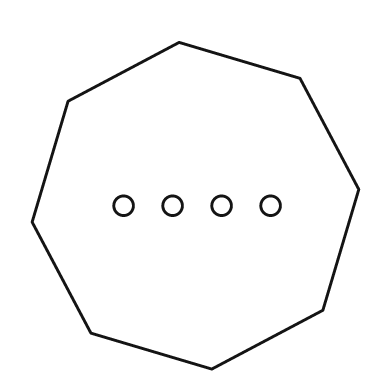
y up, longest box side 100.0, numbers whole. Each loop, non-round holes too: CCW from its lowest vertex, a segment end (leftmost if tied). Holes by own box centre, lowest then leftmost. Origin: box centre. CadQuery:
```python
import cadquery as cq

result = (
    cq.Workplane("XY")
    .moveTo(5.0, -50.0)
    .lineTo(39.0, -32.0)
    .lineTo(50.0, 5.0)
    .lineTo(32.0, 39.0)
    .lineTo(-5.0, 50.0)
    .lineTo(-39.0, 32.0)
    .lineTo(-50.0, -5.0)
    .lineTo(-32.0, -39.0)
    .close()
    .moveTo(-22.0, 0.0)
    .circle(3.0)
    .moveTo(-7.0, 0.0)
    .circle(3.0)
    .moveTo(8.0, 0.0)
    .circle(3.0)
    .moveTo(23.0, 0.0)
    .circle(3.0)
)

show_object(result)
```